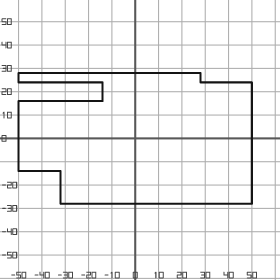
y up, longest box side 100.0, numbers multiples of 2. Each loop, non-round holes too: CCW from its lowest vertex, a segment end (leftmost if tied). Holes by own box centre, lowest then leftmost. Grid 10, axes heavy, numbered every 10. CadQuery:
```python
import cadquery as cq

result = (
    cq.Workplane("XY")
    .moveTo(-32.0, -28.0)
    .lineTo(50.0, -28.0)
    .lineTo(50.0, 24.0)
    .lineTo(28.0, 24.0)
    .lineTo(28.0, 28.0)
    .lineTo(-50.0, 28.0)
    .lineTo(-50.0, 24.0)
    .lineTo(-14.0, 24.0)
    .lineTo(-14.0, 16.0)
    .lineTo(-50.0, 16.0)
    .lineTo(-50.0, -14.0)
    .lineTo(-32.0, -14.0)
    .close()
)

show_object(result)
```